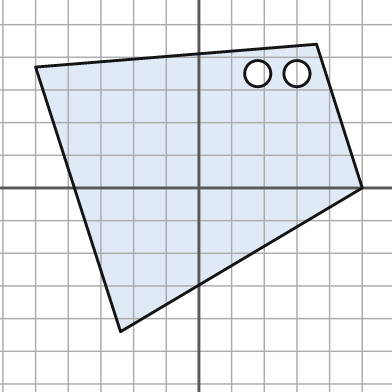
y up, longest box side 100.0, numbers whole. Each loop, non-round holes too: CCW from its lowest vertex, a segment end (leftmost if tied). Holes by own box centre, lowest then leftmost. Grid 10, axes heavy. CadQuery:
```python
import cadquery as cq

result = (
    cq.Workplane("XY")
    .moveTo(-24.0, -44.0)
    .lineTo(50.0, 0.0)
    .lineTo(36.0, 44.0)
    .lineTo(-50.0, 37.0)
    .close()
    .moveTo(18.0, 35.0)
    .circle(4.0)
    .moveTo(30.0, 35.0)
    .circle(4.0)
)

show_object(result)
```